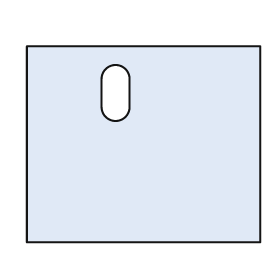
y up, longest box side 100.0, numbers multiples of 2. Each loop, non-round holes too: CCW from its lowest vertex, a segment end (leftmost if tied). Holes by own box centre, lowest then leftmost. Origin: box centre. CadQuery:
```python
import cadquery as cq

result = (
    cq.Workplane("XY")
    .moveTo(-50.0, -42.0)
    .lineTo(50.0, -42.0)
    .lineTo(50.0, 42.0)
    .lineTo(-50.0, 42.0)
    .close()
    .moveTo(-18.0, 16.0)
    .threePointArc((-12.0, 10.0), (-6.0, 16.0))
    .lineTo(-6.0, 28.0)
    .threePointArc((-12.0, 34.0), (-18.0, 28.0))
    .close()
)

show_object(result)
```